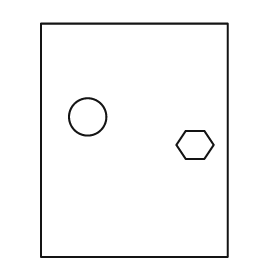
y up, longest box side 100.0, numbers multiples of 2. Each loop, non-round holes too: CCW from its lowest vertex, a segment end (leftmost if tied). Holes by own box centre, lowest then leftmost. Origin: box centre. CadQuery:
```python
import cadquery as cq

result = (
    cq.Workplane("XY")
    .moveTo(-40.0, -50.0)
    .lineTo(40.0, -50.0)
    .lineTo(40.0, 50.0)
    .lineTo(-40.0, 50.0)
    .close()
    .moveTo(22.0, -8.0)
    .lineTo(30.0, -8.0)
    .lineTo(34.0, -2.0)
    .lineTo(30.0, 4.0)
    .lineTo(22.0, 4.0)
    .lineTo(18.0, -2.0)
    .close()
    .moveTo(-20.0, 10.0)
    .circle(8.0)
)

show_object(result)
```